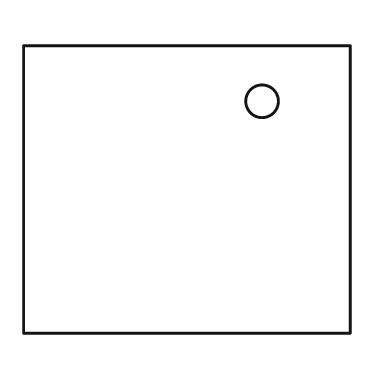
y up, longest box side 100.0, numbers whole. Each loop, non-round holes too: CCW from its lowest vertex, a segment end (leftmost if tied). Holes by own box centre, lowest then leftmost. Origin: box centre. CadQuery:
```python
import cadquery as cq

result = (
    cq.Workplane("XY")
    .moveTo(-50.0, -44.0)
    .lineTo(50.0, -44.0)
    .lineTo(50.0, 44.0)
    .lineTo(-50.0, 44.0)
    .close()
    .moveTo(23.0, 27.0)
    .circle(5.0)
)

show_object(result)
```